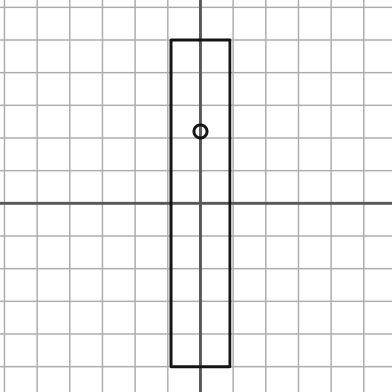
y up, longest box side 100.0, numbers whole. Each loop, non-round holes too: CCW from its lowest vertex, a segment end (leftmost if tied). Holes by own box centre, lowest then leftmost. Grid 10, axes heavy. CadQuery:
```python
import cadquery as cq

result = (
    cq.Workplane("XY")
    .moveTo(-9.0, -50.0)
    .lineTo(9.0, -50.0)
    .lineTo(9.0, 50.0)
    .lineTo(-9.0, 50.0)
    .close()
    .moveTo(0.0, 22.0)
    .circle(2.0)
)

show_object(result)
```